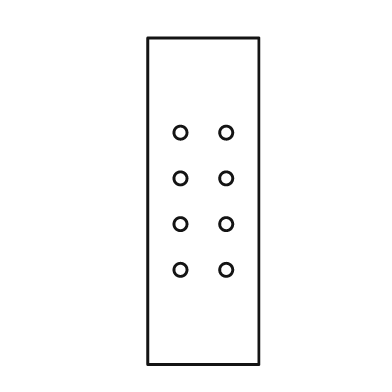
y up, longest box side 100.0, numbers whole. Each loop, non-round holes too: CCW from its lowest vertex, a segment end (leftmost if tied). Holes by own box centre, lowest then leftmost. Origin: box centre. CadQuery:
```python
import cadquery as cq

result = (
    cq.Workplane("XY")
    .moveTo(-17.0, -50.0)
    .lineTo(17.0, -50.0)
    .lineTo(17.0, 50.0)
    .lineTo(-17.0, 50.0)
    .close()
    .moveTo(-7.0, -21.0)
    .circle(2.0)
    .moveTo(7.0, -21.0)
    .circle(2.0)
    .moveTo(-7.0, -7.0)
    .circle(2.0)
    .moveTo(7.0, -7.0)
    .circle(2.0)
    .moveTo(-7.0, 7.0)
    .circle(2.0)
    .moveTo(7.0, 7.0)
    .circle(2.0)
    .moveTo(-7.0, 21.0)
    .circle(2.0)
    .moveTo(7.0, 21.0)
    .circle(2.0)
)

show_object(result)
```